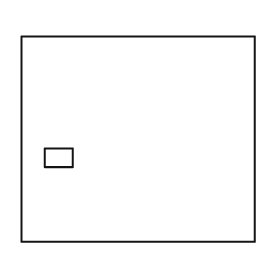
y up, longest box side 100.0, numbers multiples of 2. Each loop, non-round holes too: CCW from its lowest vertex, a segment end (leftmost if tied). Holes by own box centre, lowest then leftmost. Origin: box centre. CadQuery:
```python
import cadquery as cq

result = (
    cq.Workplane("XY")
    .moveTo(-50.0, -44.0)
    .lineTo(50.0, -44.0)
    .lineTo(50.0, 44.0)
    .lineTo(-50.0, 44.0)
    .close()
    .moveTo(-40.0, -12.0)
    .lineTo(-28.0, -12.0)
    .lineTo(-28.0, -4.0)
    .lineTo(-40.0, -4.0)
    .close()
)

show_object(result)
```